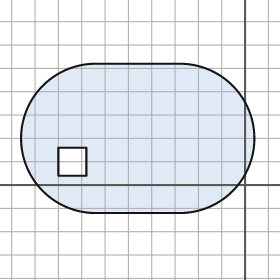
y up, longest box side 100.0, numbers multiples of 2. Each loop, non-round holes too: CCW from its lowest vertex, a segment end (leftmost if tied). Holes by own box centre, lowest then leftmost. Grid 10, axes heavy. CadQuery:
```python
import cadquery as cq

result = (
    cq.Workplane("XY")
    .moveTo(-64.0, -12.0)
    .lineTo(-28.0, -12.0)
    .threePointArc((4.0, 20.0), (-28.0, 52.0))
    .lineTo(-64.0, 52.0)
    .threePointArc((-96.0, 20.0), (-64.0, -12.0))
    .close()
    .moveTo(-80.0, 4.0)
    .lineTo(-68.0, 4.0)
    .lineTo(-68.0, 16.0)
    .lineTo(-80.0, 16.0)
    .close()
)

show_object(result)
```